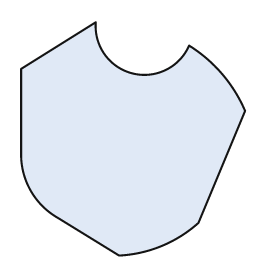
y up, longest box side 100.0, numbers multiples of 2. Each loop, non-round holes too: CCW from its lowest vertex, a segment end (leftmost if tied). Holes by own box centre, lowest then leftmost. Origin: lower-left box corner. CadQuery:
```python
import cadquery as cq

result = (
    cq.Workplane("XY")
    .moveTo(42.0, 0.0)
    .threePointArc((60.0, 4.0), (76.0, 14.0))
    .lineTo(96.0, 62.0)
    .threePointArc((86.0, 78.0), (72.0, 90.0))
    .threePointArc((48.0, 78.0), (32.0, 100.0))
    .lineTo(0.0, 80.0)
    .lineTo(0.0, 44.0)
    .threePointArc((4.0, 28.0), (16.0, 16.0))
    .close()
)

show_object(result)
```